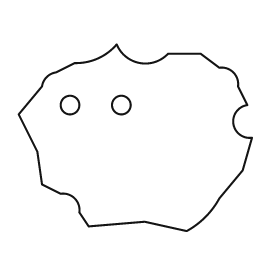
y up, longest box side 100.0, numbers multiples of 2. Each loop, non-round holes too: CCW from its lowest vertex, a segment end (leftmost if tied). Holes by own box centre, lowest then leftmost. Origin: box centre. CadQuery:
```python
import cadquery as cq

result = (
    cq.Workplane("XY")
    .moveTo(22.0, -40.0)
    .threePointArc((30.0, -34.0), (36.0, -26.0))
    .lineTo(46.0, -14.0)
    .lineTo(50.0, 0.0)
    .threePointArc((42.0, 6.0), (48.0, 14.0))
    .lineTo(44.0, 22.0)
    .threePointArc((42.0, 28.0), (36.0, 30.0))
    .lineTo(28.0, 36.0)
    .lineTo(14.0, 36.0)
    .threePointArc((2.0, 32.0), (-8.0, 40.0))
    .threePointArc((-16.0, 34.0), (-26.0, 32.0))
    .lineTo(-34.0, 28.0)
    .threePointArc((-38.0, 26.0), (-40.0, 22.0))
    .lineTo(-50.0, 10.0)
    .lineTo(-42.0, -6.0)
    .lineTo(-40.0, -20.0)
    .lineTo(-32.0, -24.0)
    .threePointArc((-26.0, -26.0), (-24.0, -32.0))
    .lineTo(-20.0, -38.0)
    .lineTo(4.0, -36.0)
    .close()
    .moveTo(-28.0, 14.0)
    .circle(4.0)
    .moveTo(-6.0, 14.0)
    .circle(4.0)
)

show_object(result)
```